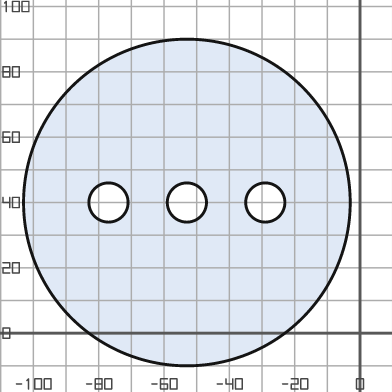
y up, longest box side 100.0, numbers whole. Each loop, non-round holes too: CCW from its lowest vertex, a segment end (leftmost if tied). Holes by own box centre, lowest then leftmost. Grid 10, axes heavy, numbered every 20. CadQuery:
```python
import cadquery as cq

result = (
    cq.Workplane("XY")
    .moveTo(-53.0, 40.0)
    .circle(50.0)
    .moveTo(-77.0, 40.0)
    .circle(6.0)
    .moveTo(-53.0, 40.0)
    .circle(6.0)
    .moveTo(-29.0, 40.0)
    .circle(6.0)
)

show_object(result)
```